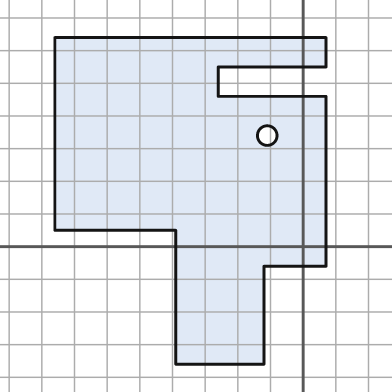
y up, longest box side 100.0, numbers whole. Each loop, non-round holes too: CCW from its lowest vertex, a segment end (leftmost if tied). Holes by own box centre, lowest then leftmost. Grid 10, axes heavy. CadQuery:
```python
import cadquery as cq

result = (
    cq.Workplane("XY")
    .moveTo(-39.0, -36.0)
    .lineTo(-12.0, -36.0)
    .lineTo(-12.0, -6.0)
    .lineTo(7.0, -6.0)
    .lineTo(7.0, 46.0)
    .lineTo(-26.0, 46.0)
    .lineTo(-26.0, 55.0)
    .lineTo(7.0, 55.0)
    .lineTo(7.0, 64.0)
    .lineTo(-76.0, 64.0)
    .lineTo(-76.0, 5.0)
    .lineTo(-39.0, 5.0)
    .close()
    .moveTo(-11.0, 34.0)
    .circle(3.0)
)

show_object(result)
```